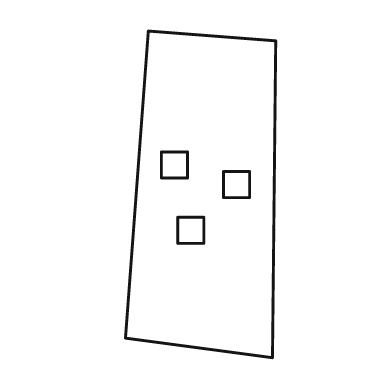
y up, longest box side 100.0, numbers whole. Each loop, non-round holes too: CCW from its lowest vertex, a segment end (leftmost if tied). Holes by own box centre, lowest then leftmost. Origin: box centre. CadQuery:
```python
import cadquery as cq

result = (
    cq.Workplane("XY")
    .moveTo(22.0, -50.0)
    .lineTo(23.0, 47.0)
    .lineTo(-16.0, 50.0)
    .lineTo(-23.0, -44.0)
    .close()
    .moveTo(-7.0, -15.0)
    .lineTo(1.0, -15.0)
    .lineTo(1.0, -7.0)
    .lineTo(-7.0, -7.0)
    .close()
    .moveTo(7.0, -1.0)
    .lineTo(15.0, -1.0)
    .lineTo(15.0, 7.0)
    .lineTo(7.0, 7.0)
    .close()
    .moveTo(-12.0, 5.0)
    .lineTo(-4.0, 5.0)
    .lineTo(-4.0, 13.0)
    .lineTo(-12.0, 13.0)
    .close()
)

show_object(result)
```